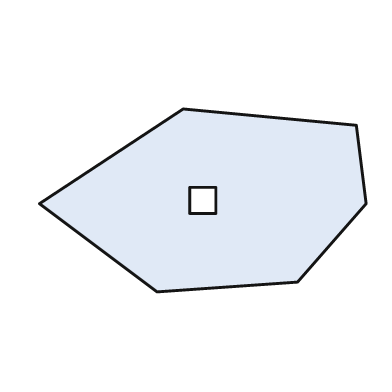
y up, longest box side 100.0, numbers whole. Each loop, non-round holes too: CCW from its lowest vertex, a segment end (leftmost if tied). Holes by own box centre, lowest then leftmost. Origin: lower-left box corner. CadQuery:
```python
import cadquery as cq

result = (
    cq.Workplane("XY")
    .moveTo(36.0, 0.0)
    .lineTo(79.0, 3.0)
    .lineTo(100.0, 27.0)
    .lineTo(97.0, 51.0)
    .lineTo(44.0, 56.0)
    .lineTo(0.0, 27.0)
    .close()
    .moveTo(46.0, 24.0)
    .lineTo(54.0, 24.0)
    .lineTo(54.0, 32.0)
    .lineTo(46.0, 32.0)
    .close()
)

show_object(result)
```